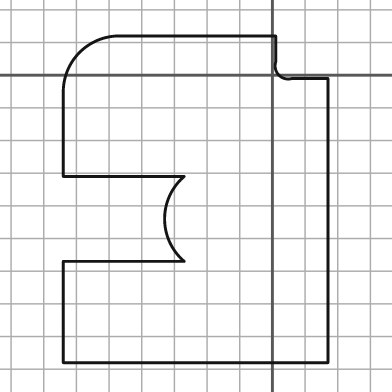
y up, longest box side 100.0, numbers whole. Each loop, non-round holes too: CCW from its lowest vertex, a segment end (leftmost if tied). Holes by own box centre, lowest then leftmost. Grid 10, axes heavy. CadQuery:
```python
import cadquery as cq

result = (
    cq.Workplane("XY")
    .moveTo(-64.0, -88.0)
    .lineTo(17.0, -88.0)
    .lineTo(17.0, -1.0)
    .lineTo(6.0, -1.0)
    .threePointArc((2.0, 0.0), (1.0, 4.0))
    .lineTo(1.0, 12.0)
    .lineTo(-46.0, 12.0)
    .threePointArc((-59.0, 7.0), (-64.0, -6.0))
    .lineTo(-64.0, -31.0)
    .lineTo(-27.0, -31.0)
    .threePointArc((-33.0, -44.0), (-27.0, -57.0))
    .lineTo(-64.0, -57.0)
    .close()
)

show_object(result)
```